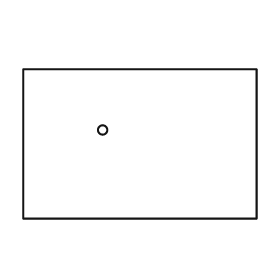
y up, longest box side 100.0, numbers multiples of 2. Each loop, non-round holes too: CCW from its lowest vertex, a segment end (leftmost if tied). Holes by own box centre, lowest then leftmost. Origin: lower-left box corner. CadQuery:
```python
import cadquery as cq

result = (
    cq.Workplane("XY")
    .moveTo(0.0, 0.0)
    .lineTo(100.0, 0.0)
    .lineTo(100.0, 64.0)
    .lineTo(0.0, 64.0)
    .close()
    .moveTo(34.0, 38.0)
    .circle(2.0)
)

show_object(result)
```